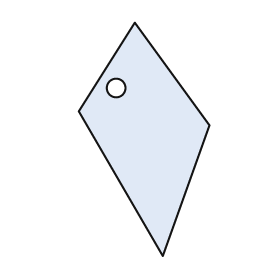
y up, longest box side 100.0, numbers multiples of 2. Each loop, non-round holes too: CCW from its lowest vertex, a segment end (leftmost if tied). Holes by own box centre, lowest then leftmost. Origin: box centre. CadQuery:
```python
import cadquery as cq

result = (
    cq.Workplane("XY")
    .moveTo(8.0, -50.0)
    .lineTo(28.0, 6.0)
    .lineTo(-4.0, 50.0)
    .lineTo(-28.0, 12.0)
    .close()
    .moveTo(-12.0, 22.0)
    .circle(4.0)
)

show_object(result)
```